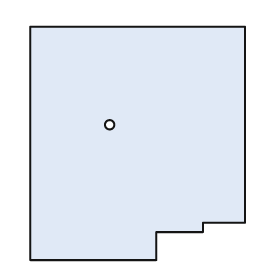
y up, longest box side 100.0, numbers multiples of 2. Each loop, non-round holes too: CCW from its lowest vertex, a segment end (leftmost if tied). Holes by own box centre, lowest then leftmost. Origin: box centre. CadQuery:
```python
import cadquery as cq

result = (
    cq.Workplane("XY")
    .moveTo(-46.0, -50.0)
    .lineTo(8.0, -50.0)
    .lineTo(8.0, -38.0)
    .lineTo(28.0, -38.0)
    .lineTo(28.0, -34.0)
    .lineTo(46.0, -34.0)
    .lineTo(46.0, 50.0)
    .lineTo(-46.0, 50.0)
    .close()
    .moveTo(-12.0, 8.0)
    .circle(2.0)
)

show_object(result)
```